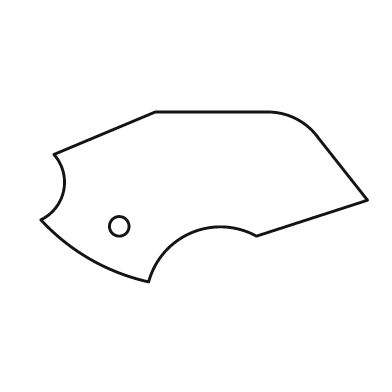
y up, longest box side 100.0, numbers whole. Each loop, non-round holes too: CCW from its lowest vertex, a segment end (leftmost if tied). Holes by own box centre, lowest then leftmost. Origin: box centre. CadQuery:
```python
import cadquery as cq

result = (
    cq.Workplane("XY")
    .moveTo(-17.0, -26.0)
    .threePointArc((-4.0, -11.0), (16.0, -12.0))
    .lineTo(50.0, -1.0)
    .lineTo(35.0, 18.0)
    .threePointArc((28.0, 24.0), (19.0, 26.0))
    .lineTo(-15.0, 26.0)
    .lineTo(-46.0, 13.0)
    .threePointArc((-43.0, 2.0), (-50.0, -7.0))
    .threePointArc((-35.0, -19.0), (-17.0, -26.0))
    .close()
    .moveTo(-26.0, -9.0)
    .circle(3.0)
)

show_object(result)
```